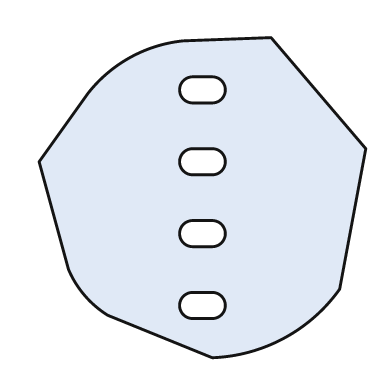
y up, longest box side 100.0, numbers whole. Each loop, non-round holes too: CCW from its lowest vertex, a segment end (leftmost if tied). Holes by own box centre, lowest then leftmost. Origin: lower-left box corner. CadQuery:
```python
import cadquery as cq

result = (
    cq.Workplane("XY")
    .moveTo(53.0, 0.0)
    .threePointArc((75.0, 6.0), (92.0, 21.0))
    .lineTo(100.0, 64.0)
    .lineTo(71.0, 98.0)
    .lineTo(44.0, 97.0)
    .threePointArc((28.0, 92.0), (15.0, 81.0))
    .lineTo(0.0, 60.0)
    .lineTo(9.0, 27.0)
    .threePointArc((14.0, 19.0), (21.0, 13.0))
    .close()
    .moveTo(47.0, 12.0)
    .lineTo(53.0, 12.0)
    .threePointArc((57.0, 16.0), (53.0, 20.0))
    .lineTo(47.0, 20.0)
    .threePointArc((43.0, 16.0), (47.0, 12.0))
    .close()
    .moveTo(47.0, 34.0)
    .lineTo(53.0, 34.0)
    .threePointArc((57.0, 38.0), (53.0, 42.0))
    .lineTo(47.0, 42.0)
    .threePointArc((43.0, 38.0), (47.0, 34.0))
    .close()
    .moveTo(47.0, 56.0)
    .lineTo(53.0, 56.0)
    .threePointArc((57.0, 60.0), (53.0, 64.0))
    .lineTo(47.0, 64.0)
    .threePointArc((43.0, 60.0), (47.0, 56.0))
    .close()
    .moveTo(47.0, 78.0)
    .lineTo(53.0, 78.0)
    .threePointArc((57.0, 82.0), (53.0, 86.0))
    .lineTo(47.0, 86.0)
    .threePointArc((43.0, 82.0), (47.0, 78.0))
    .close()
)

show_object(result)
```